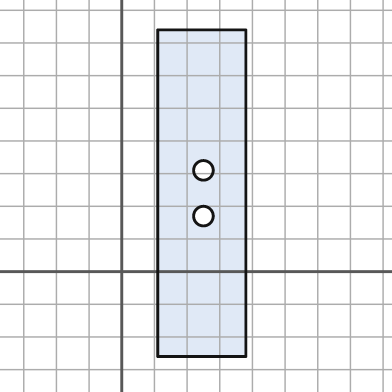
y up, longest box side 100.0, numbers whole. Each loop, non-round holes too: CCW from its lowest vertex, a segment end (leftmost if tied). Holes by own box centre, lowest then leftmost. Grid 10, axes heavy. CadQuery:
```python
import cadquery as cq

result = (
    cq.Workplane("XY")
    .moveTo(11.0, -26.0)
    .lineTo(38.0, -26.0)
    .lineTo(38.0, 74.0)
    .lineTo(11.0, 74.0)
    .close()
    .moveTo(25.0, 17.0)
    .circle(3.0)
    .moveTo(25.0, 31.0)
    .circle(3.0)
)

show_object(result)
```